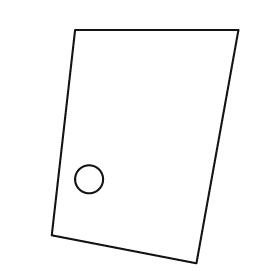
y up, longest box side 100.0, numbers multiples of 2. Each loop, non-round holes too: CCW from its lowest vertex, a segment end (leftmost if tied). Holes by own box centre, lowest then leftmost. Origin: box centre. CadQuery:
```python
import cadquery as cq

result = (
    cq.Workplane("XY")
    .moveTo(22.0, -50.0)
    .lineTo(40.0, 50.0)
    .lineTo(-30.0, 50.0)
    .lineTo(-40.0, -38.0)
    .close()
    .moveTo(-24.0, -14.0)
    .circle(6.0)
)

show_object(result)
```